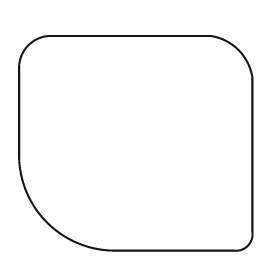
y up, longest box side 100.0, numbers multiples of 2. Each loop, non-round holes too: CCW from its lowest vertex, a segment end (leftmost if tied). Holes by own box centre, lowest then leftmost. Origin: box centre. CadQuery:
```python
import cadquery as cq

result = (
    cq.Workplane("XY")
    .moveTo(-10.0, -46.0)
    .lineTo(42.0, -46.0)
    .threePointArc((48.0, -44.0), (50.0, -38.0))
    .lineTo(50.0, 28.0)
    .threePointArc((44.0, 40.0), (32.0, 46.0))
    .lineTo(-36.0, 46.0)
    .threePointArc((-46.0, 42.0), (-50.0, 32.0))
    .lineTo(-50.0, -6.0)
    .threePointArc((-38.0, -34.0), (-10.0, -46.0))
    .close()
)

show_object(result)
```